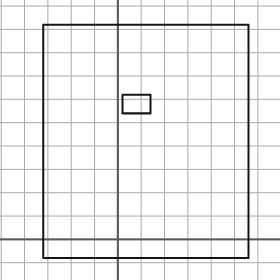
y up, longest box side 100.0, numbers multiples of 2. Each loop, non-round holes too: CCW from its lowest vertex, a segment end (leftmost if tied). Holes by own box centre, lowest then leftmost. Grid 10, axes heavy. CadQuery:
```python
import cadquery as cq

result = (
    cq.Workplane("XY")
    .moveTo(-32.0, -8.0)
    .lineTo(56.0, -8.0)
    .lineTo(56.0, 92.0)
    .lineTo(-32.0, 92.0)
    .close()
    .moveTo(2.0, 54.0)
    .lineTo(14.0, 54.0)
    .lineTo(14.0, 62.0)
    .lineTo(2.0, 62.0)
    .close()
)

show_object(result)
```